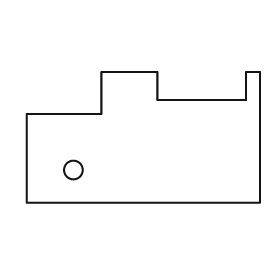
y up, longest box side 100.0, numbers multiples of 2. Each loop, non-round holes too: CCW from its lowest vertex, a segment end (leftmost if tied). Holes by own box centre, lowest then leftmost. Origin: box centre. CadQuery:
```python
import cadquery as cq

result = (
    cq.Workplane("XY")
    .moveTo(-50.0, -28.0)
    .lineTo(50.0, -28.0)
    .lineTo(50.0, 28.0)
    .lineTo(44.0, 28.0)
    .lineTo(44.0, 16.0)
    .lineTo(6.0, 16.0)
    .lineTo(6.0, 28.0)
    .lineTo(-18.0, 28.0)
    .lineTo(-18.0, 10.0)
    .lineTo(-50.0, 10.0)
    .close()
    .moveTo(-30.0, -14.0)
    .circle(4.0)
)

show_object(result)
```